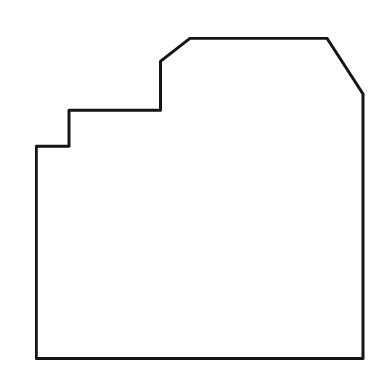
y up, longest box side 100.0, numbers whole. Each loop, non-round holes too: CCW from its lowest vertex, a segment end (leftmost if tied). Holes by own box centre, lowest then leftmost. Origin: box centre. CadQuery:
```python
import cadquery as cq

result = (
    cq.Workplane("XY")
    .moveTo(-50.0, -49.0)
    .lineTo(50.0, -49.0)
    .lineTo(50.0, 32.0)
    .lineTo(39.0, 49.0)
    .lineTo(-3.0, 49.0)
    .lineTo(-12.0, 42.0)
    .lineTo(-12.0, 27.0)
    .lineTo(-40.0, 27.0)
    .lineTo(-40.0, 16.0)
    .lineTo(-50.0, 16.0)
    .close()
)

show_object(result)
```